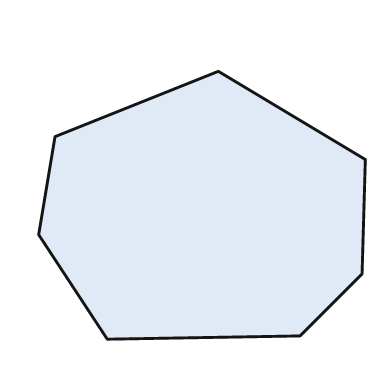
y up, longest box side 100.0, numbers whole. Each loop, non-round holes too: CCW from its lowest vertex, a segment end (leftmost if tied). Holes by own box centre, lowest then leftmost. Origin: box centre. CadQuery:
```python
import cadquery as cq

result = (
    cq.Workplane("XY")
    .moveTo(-29.0, -41.0)
    .lineTo(30.0, -40.0)
    .lineTo(49.0, -21.0)
    .lineTo(50.0, 14.0)
    .lineTo(5.0, 41.0)
    .lineTo(-45.0, 21.0)
    .lineTo(-50.0, -9.0)
    .close()
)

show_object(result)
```